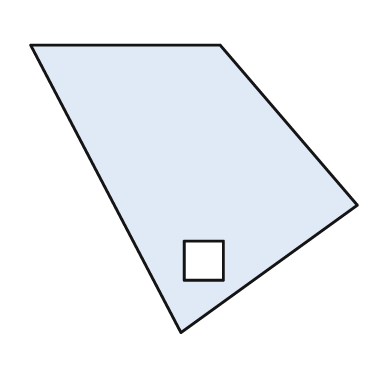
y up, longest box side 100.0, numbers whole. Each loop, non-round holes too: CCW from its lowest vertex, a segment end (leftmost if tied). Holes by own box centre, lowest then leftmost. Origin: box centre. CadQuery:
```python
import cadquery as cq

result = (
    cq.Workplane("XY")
    .moveTo(-4.0, -44.0)
    .lineTo(50.0, -5.0)
    .lineTo(8.0, 44.0)
    .lineTo(-50.0, 44.0)
    .close()
    .moveTo(-3.0, -28.0)
    .lineTo(9.0, -28.0)
    .lineTo(9.0, -16.0)
    .lineTo(-3.0, -16.0)
    .close()
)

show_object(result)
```